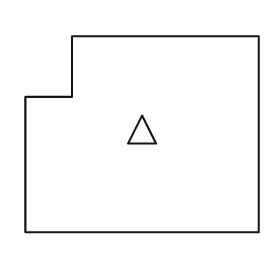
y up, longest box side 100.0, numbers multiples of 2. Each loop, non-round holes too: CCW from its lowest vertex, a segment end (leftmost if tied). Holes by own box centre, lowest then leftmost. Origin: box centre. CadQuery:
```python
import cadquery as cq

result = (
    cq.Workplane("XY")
    .moveTo(-50.0, -42.0)
    .lineTo(50.0, -42.0)
    .lineTo(50.0, 42.0)
    .lineTo(-30.0, 42.0)
    .lineTo(-30.0, 16.0)
    .lineTo(-50.0, 16.0)
    .close()
    .moveTo(-6.0, -4.0)
    .lineTo(6.0, -4.0)
    .lineTo(0.0, 8.0)
    .close()
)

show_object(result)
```